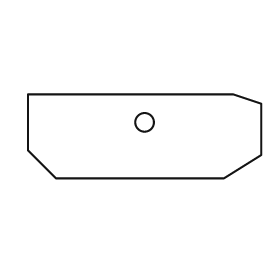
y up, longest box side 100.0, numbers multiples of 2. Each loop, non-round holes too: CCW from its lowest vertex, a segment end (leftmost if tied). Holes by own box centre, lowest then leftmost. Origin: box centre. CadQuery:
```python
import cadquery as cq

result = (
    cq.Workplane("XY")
    .moveTo(-38.0, -18.0)
    .lineTo(34.0, -18.0)
    .lineTo(50.0, -8.0)
    .lineTo(50.0, 14.0)
    .lineTo(38.0, 18.0)
    .lineTo(-50.0, 18.0)
    .lineTo(-50.0, -6.0)
    .close()
    .moveTo(0.0, 6.0)
    .circle(4.0)
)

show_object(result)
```